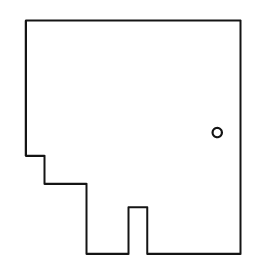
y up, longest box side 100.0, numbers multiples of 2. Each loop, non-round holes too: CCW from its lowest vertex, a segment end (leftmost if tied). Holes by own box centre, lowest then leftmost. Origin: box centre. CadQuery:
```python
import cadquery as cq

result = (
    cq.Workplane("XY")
    .moveTo(-20.0, -50.0)
    .lineTo(-2.0, -50.0)
    .lineTo(-2.0, -30.0)
    .lineTo(6.0, -30.0)
    .lineTo(6.0, -50.0)
    .lineTo(46.0, -50.0)
    .lineTo(46.0, 50.0)
    .lineTo(-46.0, 50.0)
    .lineTo(-46.0, -8.0)
    .lineTo(-38.0, -8.0)
    .lineTo(-38.0, -20.0)
    .lineTo(-20.0, -20.0)
    .close()
    .moveTo(36.0, 2.0)
    .circle(2.0)
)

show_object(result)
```